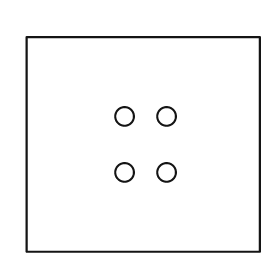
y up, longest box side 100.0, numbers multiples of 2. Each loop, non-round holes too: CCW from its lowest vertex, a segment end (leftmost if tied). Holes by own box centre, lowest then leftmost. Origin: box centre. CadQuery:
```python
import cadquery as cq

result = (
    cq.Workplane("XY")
    .moveTo(-50.0, -46.0)
    .lineTo(50.0, -46.0)
    .lineTo(50.0, 46.0)
    .lineTo(-50.0, 46.0)
    .close()
    .moveTo(-8.0, -12.0)
    .circle(4.0)
    .moveTo(10.0, -12.0)
    .circle(4.0)
    .moveTo(-8.0, 12.0)
    .circle(4.0)
    .moveTo(10.0, 12.0)
    .circle(4.0)
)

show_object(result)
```